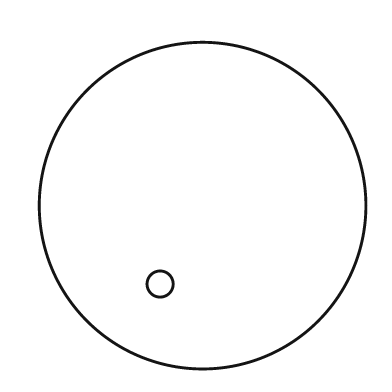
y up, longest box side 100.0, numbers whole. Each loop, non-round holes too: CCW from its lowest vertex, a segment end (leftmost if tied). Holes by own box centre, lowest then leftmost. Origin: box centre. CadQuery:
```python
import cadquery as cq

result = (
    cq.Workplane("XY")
    .moveTo(0.0, 0.0)
    .circle(50.0)
    .moveTo(-13.0, -24.0)
    .circle(4.0)
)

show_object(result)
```